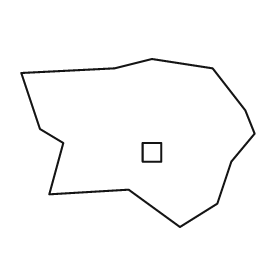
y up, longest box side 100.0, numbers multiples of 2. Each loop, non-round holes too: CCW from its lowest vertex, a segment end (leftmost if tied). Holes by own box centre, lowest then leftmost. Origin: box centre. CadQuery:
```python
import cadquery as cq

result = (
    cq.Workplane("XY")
    .moveTo(18.0, -36.0)
    .lineTo(34.0, -26.0)
    .lineTo(40.0, -8.0)
    .lineTo(50.0, 4.0)
    .lineTo(46.0, 14.0)
    .lineTo(32.0, 32.0)
    .lineTo(6.0, 36.0)
    .lineTo(-10.0, 32.0)
    .lineTo(-50.0, 30.0)
    .lineTo(-42.0, 6.0)
    .lineTo(-32.0, 0.0)
    .lineTo(-38.0, -22.0)
    .lineTo(-4.0, -20.0)
    .close()
    .moveTo(2.0, -8.0)
    .lineTo(10.0, -8.0)
    .lineTo(10.0, 0.0)
    .lineTo(2.0, 0.0)
    .close()
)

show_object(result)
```